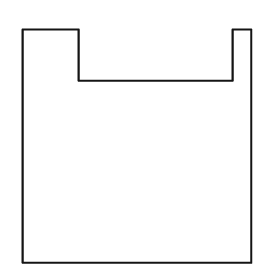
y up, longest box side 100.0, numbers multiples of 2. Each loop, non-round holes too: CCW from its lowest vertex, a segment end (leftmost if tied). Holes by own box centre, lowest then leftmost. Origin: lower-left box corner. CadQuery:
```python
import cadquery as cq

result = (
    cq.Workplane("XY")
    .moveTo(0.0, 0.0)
    .lineTo(98.0, 0.0)
    .lineTo(98.0, 100.0)
    .lineTo(90.0, 100.0)
    .lineTo(90.0, 78.0)
    .lineTo(24.0, 78.0)
    .lineTo(24.0, 100.0)
    .lineTo(0.0, 100.0)
    .close()
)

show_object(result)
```